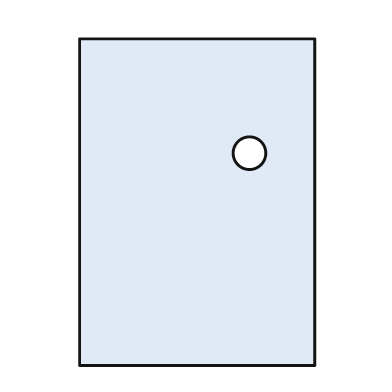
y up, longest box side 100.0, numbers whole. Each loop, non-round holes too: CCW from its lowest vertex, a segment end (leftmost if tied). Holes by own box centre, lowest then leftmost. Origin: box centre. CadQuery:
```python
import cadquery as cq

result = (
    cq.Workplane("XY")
    .moveTo(-36.0, -50.0)
    .lineTo(36.0, -50.0)
    .lineTo(36.0, 50.0)
    .lineTo(-36.0, 50.0)
    .close()
    .moveTo(16.0, 15.0)
    .circle(5.0)
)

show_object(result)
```